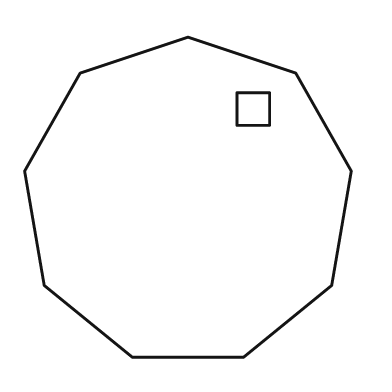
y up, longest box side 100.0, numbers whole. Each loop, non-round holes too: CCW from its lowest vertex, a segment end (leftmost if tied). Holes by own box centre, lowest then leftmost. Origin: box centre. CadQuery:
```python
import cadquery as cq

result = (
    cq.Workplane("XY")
    .moveTo(-17.0, -49.0)
    .lineTo(17.0, -49.0)
    .lineTo(44.0, -27.0)
    .lineTo(50.0, 8.0)
    .lineTo(33.0, 38.0)
    .lineTo(0.0, 49.0)
    .lineTo(-33.0, 38.0)
    .lineTo(-50.0, 8.0)
    .lineTo(-44.0, -27.0)
    .close()
    .moveTo(15.0, 22.0)
    .lineTo(25.0, 22.0)
    .lineTo(25.0, 32.0)
    .lineTo(15.0, 32.0)
    .close()
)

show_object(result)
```